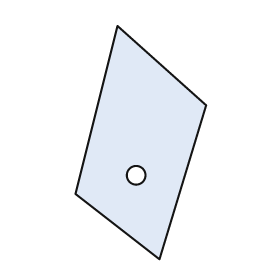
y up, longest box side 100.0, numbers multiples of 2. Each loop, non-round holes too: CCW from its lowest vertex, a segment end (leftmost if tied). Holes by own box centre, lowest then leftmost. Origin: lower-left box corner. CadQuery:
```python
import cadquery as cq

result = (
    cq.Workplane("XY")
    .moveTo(36.0, 0.0)
    .lineTo(56.0, 66.0)
    .lineTo(18.0, 100.0)
    .lineTo(0.0, 28.0)
    .close()
    .moveTo(26.0, 36.0)
    .circle(4.0)
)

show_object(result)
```